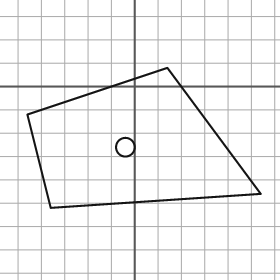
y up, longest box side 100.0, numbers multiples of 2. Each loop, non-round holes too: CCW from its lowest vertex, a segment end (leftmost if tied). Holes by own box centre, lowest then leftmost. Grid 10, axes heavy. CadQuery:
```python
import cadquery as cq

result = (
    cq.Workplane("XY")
    .moveTo(-36.0, -52.0)
    .lineTo(54.0, -46.0)
    .lineTo(14.0, 8.0)
    .lineTo(-46.0, -12.0)
    .close()
    .moveTo(-4.0, -26.0)
    .circle(4.0)
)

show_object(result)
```